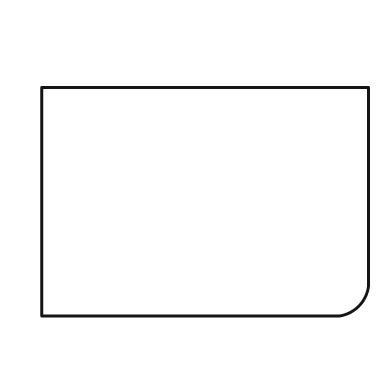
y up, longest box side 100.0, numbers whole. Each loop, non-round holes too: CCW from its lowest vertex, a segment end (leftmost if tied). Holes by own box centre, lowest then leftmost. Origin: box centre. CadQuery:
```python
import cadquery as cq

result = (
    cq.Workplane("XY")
    .moveTo(-50.0, -35.0)
    .lineTo(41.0, -35.0)
    .threePointArc((47.0, -32.0), (50.0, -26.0))
    .lineTo(50.0, 35.0)
    .lineTo(-50.0, 35.0)
    .close()
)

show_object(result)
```